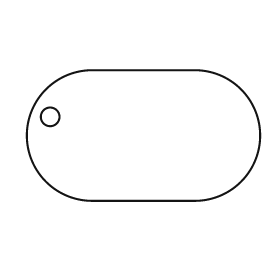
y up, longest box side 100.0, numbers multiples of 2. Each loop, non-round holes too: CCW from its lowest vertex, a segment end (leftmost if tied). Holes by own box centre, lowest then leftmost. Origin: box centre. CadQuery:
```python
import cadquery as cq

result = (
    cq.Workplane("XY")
    .moveTo(-22.0, -28.0)
    .lineTo(22.0, -28.0)
    .threePointArc((50.0, 0.0), (22.0, 28.0))
    .lineTo(-22.0, 28.0)
    .threePointArc((-50.0, 0.0), (-22.0, -28.0))
    .close()
    .moveTo(-40.0, 8.0)
    .circle(4.0)
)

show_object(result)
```